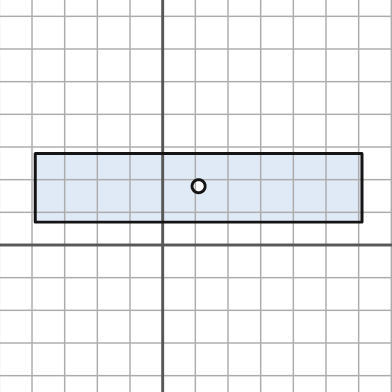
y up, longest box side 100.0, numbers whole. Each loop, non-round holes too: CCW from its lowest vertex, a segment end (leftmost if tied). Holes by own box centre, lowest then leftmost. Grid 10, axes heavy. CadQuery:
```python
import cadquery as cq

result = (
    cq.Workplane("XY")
    .moveTo(-39.0, 7.0)
    .lineTo(61.0, 7.0)
    .lineTo(61.0, 28.0)
    .lineTo(-39.0, 28.0)
    .close()
    .moveTo(11.0, 18.0)
    .circle(2.0)
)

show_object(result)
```